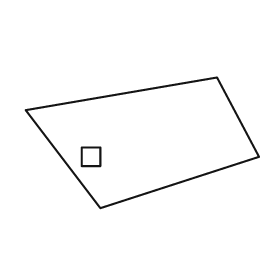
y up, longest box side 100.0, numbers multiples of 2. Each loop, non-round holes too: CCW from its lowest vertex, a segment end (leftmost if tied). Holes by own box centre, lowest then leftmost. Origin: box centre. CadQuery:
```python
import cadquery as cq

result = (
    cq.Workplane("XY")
    .moveTo(-18.0, -28.0)
    .lineTo(50.0, -6.0)
    .lineTo(32.0, 28.0)
    .lineTo(-50.0, 14.0)
    .close()
    .moveTo(-26.0, -10.0)
    .lineTo(-18.0, -10.0)
    .lineTo(-18.0, -2.0)
    .lineTo(-26.0, -2.0)
    .close()
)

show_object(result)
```